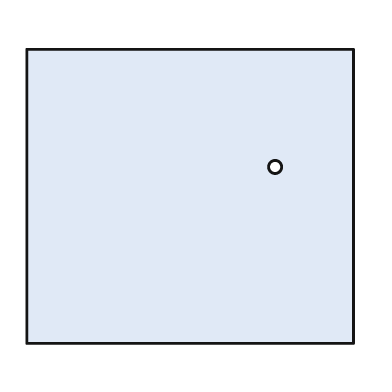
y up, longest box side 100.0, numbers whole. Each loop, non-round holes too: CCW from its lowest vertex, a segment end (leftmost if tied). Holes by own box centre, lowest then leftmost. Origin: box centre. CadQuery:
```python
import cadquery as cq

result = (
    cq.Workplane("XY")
    .moveTo(-50.0, -45.0)
    .lineTo(50.0, -45.0)
    .lineTo(50.0, 45.0)
    .lineTo(-50.0, 45.0)
    .close()
    .moveTo(26.0, 9.0)
    .circle(2.0)
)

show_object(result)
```